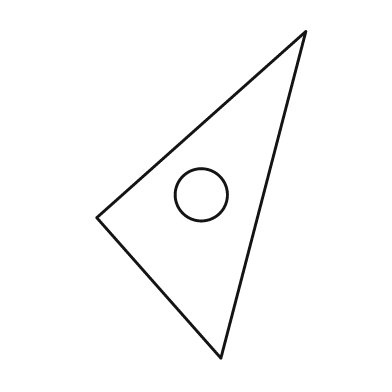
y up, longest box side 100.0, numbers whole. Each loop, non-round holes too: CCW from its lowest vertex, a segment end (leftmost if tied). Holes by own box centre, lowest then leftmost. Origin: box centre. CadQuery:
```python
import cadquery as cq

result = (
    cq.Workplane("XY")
    .moveTo(6.0, -50.0)
    .lineTo(32.0, 50.0)
    .lineTo(-32.0, -7.0)
    .close()
    .moveTo(0.0, 0.0)
    .circle(8.0)
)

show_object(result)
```